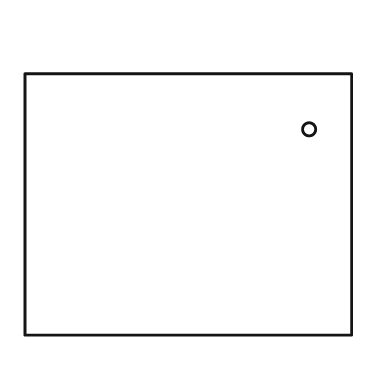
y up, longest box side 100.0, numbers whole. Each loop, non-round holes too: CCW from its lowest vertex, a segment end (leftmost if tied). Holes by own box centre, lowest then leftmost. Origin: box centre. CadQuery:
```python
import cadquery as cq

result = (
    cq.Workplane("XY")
    .moveTo(-50.0, -40.0)
    .lineTo(50.0, -40.0)
    .lineTo(50.0, 40.0)
    .lineTo(-50.0, 40.0)
    .close()
    .moveTo(37.0, 23.0)
    .circle(2.0)
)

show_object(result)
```